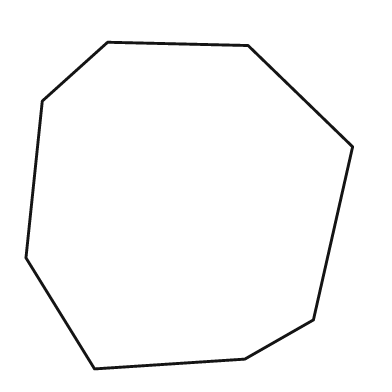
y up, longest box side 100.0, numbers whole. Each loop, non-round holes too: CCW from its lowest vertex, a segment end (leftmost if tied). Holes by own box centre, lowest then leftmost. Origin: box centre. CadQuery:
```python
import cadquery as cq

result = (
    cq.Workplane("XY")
    .moveTo(-29.0, -50.0)
    .lineTo(17.0, -47.0)
    .lineTo(38.0, -35.0)
    .lineTo(50.0, 18.0)
    .lineTo(18.0, 49.0)
    .lineTo(-25.0, 50.0)
    .lineTo(-45.0, 32.0)
    .lineTo(-50.0, -16.0)
    .close()
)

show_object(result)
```